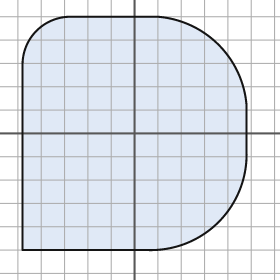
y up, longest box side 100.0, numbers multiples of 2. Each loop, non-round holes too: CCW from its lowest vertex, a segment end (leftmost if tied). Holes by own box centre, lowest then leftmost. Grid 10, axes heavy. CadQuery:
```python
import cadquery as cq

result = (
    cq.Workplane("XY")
    .moveTo(-48.0, -50.0)
    .lineTo(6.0, -50.0)
    .threePointArc((36.0, -38.0), (48.0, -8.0))
    .lineTo(48.0, 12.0)
    .threePointArc((36.0, 38.0), (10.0, 50.0))
    .lineTo(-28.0, 50.0)
    .threePointArc((-42.0, 44.0), (-48.0, 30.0))
    .close()
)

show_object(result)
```